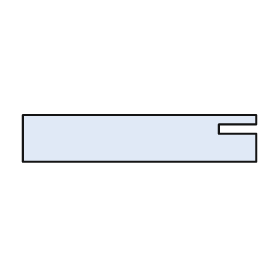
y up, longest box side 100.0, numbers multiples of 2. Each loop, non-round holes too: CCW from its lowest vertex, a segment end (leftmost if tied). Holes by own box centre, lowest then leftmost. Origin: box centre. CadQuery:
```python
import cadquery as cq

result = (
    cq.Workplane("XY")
    .moveTo(-50.0, -10.0)
    .lineTo(50.0, -10.0)
    .lineTo(50.0, 2.0)
    .lineTo(34.0, 2.0)
    .lineTo(34.0, 6.0)
    .lineTo(50.0, 6.0)
    .lineTo(50.0, 10.0)
    .lineTo(-50.0, 10.0)
    .close()
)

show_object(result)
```